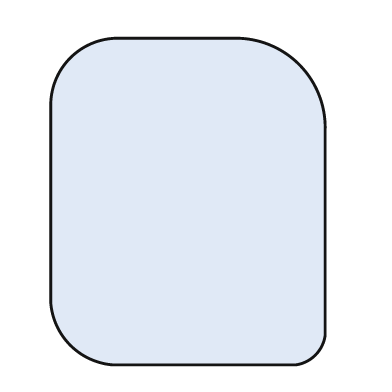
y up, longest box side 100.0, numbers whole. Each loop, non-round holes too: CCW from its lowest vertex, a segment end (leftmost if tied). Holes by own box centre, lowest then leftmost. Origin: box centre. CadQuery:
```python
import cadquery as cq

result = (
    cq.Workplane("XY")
    .moveTo(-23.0, -50.0)
    .lineTo(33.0, -50.0)
    .threePointArc((39.0, -47.0), (42.0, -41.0))
    .lineTo(42.0, 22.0)
    .threePointArc((34.0, 42.0), (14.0, 50.0))
    .lineTo(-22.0, 50.0)
    .threePointArc((-36.0, 44.0), (-42.0, 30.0))
    .lineTo(-42.0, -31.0)
    .threePointArc((-36.0, -44.0), (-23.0, -50.0))
    .close()
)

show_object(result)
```